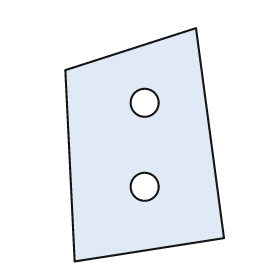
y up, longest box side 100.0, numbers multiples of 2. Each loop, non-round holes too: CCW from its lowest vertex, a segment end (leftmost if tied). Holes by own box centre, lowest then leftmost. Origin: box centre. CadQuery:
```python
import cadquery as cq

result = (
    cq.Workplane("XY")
    .moveTo(-30.0, -50.0)
    .lineTo(34.0, -40.0)
    .lineTo(22.0, 50.0)
    .lineTo(-34.0, 32.0)
    .close()
    .moveTo(0.0, -18.0)
    .circle(6.0)
    .moveTo(0.0, 18.0)
    .circle(6.0)
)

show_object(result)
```